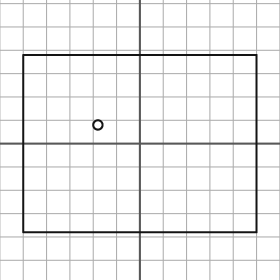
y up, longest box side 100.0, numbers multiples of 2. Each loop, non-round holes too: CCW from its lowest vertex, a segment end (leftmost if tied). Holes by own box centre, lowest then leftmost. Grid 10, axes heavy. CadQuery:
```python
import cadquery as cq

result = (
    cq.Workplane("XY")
    .moveTo(-50.0, -38.0)
    .lineTo(50.0, -38.0)
    .lineTo(50.0, 38.0)
    .lineTo(-50.0, 38.0)
    .close()
    .moveTo(-18.0, 8.0)
    .circle(2.0)
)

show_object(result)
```